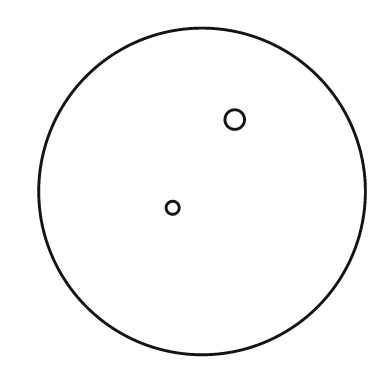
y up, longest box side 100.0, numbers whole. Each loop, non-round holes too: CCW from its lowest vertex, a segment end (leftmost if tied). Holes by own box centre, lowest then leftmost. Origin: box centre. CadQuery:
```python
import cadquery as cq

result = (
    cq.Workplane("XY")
    .moveTo(0.0, 0.0)
    .circle(50.0)
    .moveTo(-9.0, -5.0)
    .circle(2.0)
    .moveTo(10.0, 22.0)
    .circle(3.0)
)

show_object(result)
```